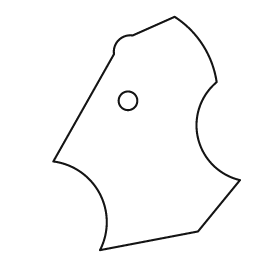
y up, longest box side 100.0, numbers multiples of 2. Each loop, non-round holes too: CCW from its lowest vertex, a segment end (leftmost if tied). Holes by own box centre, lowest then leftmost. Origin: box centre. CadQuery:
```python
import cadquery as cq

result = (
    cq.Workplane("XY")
    .moveTo(-20.0, -50.0)
    .lineTo(22.0, -42.0)
    .lineTo(40.0, -20.0)
    .threePointArc((22.0, -2.0), (30.0, 22.0))
    .threePointArc((24.0, 38.0), (12.0, 50.0))
    .lineTo(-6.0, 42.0)
    .threePointArc((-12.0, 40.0), (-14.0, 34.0))
    .lineTo(-40.0, -12.0)
    .threePointArc((-20.0, -26.0), (-20.0, -50.0))
    .close()
    .moveTo(-8.0, 14.0)
    .circle(4.0)
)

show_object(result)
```